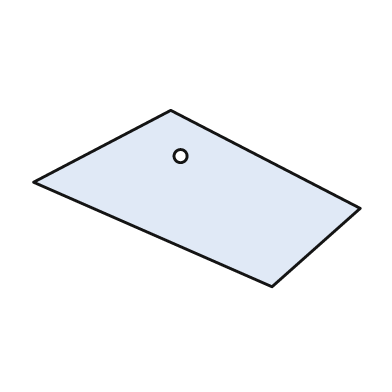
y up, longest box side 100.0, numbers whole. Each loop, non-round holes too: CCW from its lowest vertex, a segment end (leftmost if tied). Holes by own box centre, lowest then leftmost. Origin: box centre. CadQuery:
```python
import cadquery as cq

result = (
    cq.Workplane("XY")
    .moveTo(23.0, -27.0)
    .lineTo(50.0, -3.0)
    .lineTo(-8.0, 27.0)
    .lineTo(-50.0, 5.0)
    .close()
    .moveTo(-5.0, 13.0)
    .circle(2.0)
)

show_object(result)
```